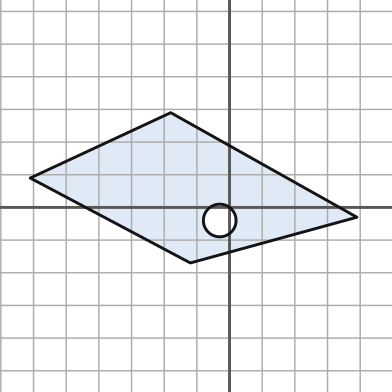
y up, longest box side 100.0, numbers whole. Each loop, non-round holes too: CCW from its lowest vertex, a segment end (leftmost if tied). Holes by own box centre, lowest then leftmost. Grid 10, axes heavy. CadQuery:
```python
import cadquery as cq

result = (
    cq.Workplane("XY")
    .moveTo(-12.0, -17.0)
    .lineTo(39.0, -3.0)
    .lineTo(-18.0, 29.0)
    .lineTo(-61.0, 9.0)
    .close()
    .moveTo(-3.0, -4.0)
    .circle(5.0)
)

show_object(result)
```